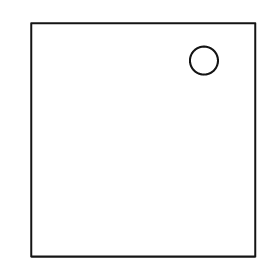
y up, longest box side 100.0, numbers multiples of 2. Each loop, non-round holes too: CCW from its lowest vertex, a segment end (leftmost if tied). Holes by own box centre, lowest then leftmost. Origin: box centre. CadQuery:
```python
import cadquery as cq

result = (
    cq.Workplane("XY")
    .moveTo(-48.0, -50.0)
    .lineTo(48.0, -50.0)
    .lineTo(48.0, 50.0)
    .lineTo(-48.0, 50.0)
    .close()
    .moveTo(26.0, 34.0)
    .circle(6.0)
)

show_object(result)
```